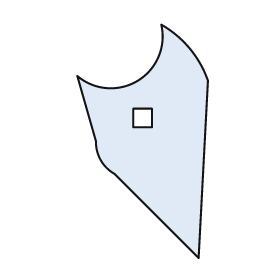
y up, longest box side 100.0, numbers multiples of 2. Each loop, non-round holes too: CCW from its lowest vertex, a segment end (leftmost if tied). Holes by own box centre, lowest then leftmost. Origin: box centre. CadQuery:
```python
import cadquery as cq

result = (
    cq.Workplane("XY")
    .moveTo(24.0, -50.0)
    .lineTo(28.0, 26.0)
    .threePointArc((20.0, 40.0), (8.0, 50.0))
    .threePointArc((-2.0, 26.0), (-28.0, 28.0))
    .lineTo(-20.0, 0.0)
    .threePointArc((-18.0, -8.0), (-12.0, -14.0))
    .close()
    .moveTo(-4.0, 6.0)
    .lineTo(4.0, 6.0)
    .lineTo(4.0, 14.0)
    .lineTo(-4.0, 14.0)
    .close()
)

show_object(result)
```